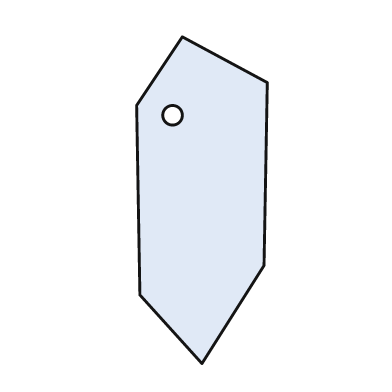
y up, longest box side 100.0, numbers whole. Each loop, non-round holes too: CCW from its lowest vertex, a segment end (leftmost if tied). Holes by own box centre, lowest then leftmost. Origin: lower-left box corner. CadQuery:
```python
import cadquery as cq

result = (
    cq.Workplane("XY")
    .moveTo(20.0, 0.0)
    .lineTo(39.0, 30.0)
    .lineTo(40.0, 86.0)
    .lineTo(14.0, 100.0)
    .lineTo(0.0, 79.0)
    .lineTo(1.0, 21.0)
    .close()
    .moveTo(11.0, 76.0)
    .circle(3.0)
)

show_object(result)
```